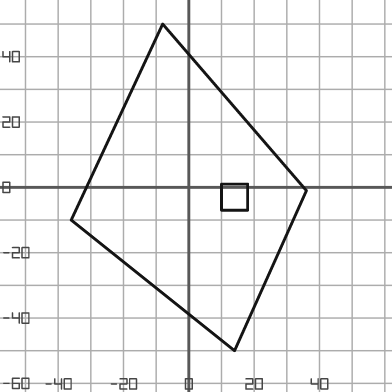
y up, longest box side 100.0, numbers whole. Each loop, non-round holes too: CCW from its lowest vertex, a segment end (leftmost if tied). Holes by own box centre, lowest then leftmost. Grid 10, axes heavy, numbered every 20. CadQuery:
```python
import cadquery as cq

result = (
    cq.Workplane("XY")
    .moveTo(14.0, -50.0)
    .lineTo(36.0, -1.0)
    .lineTo(-8.0, 50.0)
    .lineTo(-36.0, -10.0)
    .close()
    .moveTo(10.0, -7.0)
    .lineTo(18.0, -7.0)
    .lineTo(18.0, 1.0)
    .lineTo(10.0, 1.0)
    .close()
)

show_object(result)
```